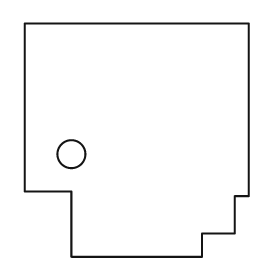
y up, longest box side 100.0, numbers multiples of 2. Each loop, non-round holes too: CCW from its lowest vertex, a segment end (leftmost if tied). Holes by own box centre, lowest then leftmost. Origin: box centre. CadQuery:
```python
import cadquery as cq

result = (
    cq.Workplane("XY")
    .moveTo(-28.0, -50.0)
    .lineTo(28.0, -50.0)
    .lineTo(28.0, -40.0)
    .lineTo(42.0, -40.0)
    .lineTo(42.0, -24.0)
    .lineTo(48.0, -24.0)
    .lineTo(48.0, 50.0)
    .lineTo(-48.0, 50.0)
    .lineTo(-48.0, -22.0)
    .lineTo(-28.0, -22.0)
    .close()
    .moveTo(-28.0, -6.0)
    .circle(6.0)
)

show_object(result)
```